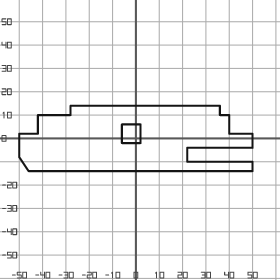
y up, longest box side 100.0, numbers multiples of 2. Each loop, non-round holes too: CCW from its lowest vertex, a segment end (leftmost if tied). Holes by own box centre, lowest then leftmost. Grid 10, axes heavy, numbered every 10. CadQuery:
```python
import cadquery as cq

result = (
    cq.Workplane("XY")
    .moveTo(-46.0, -14.0)
    .lineTo(50.0, -14.0)
    .lineTo(50.0, -10.0)
    .lineTo(22.0, -10.0)
    .lineTo(22.0, -4.0)
    .lineTo(50.0, -4.0)
    .lineTo(50.0, 2.0)
    .lineTo(40.0, 2.0)
    .lineTo(40.0, 10.0)
    .lineTo(36.0, 10.0)
    .lineTo(36.0, 14.0)
    .lineTo(-28.0, 14.0)
    .lineTo(-28.0, 10.0)
    .lineTo(-42.0, 10.0)
    .lineTo(-42.0, 2.0)
    .lineTo(-50.0, 2.0)
    .lineTo(-50.0, -8.0)
    .close()
    .moveTo(-6.0, -2.0)
    .lineTo(2.0, -2.0)
    .lineTo(2.0, 6.0)
    .lineTo(-6.0, 6.0)
    .close()
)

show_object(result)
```